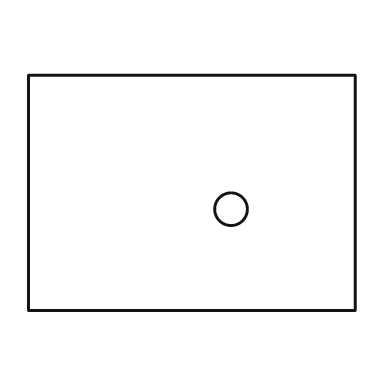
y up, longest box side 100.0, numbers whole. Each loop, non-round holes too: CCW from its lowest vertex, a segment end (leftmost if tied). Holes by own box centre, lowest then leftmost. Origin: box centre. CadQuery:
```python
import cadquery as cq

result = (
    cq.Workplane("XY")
    .moveTo(-50.0, -36.0)
    .lineTo(50.0, -36.0)
    .lineTo(50.0, 36.0)
    .lineTo(-50.0, 36.0)
    .close()
    .moveTo(12.0, -5.0)
    .circle(5.0)
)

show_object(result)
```